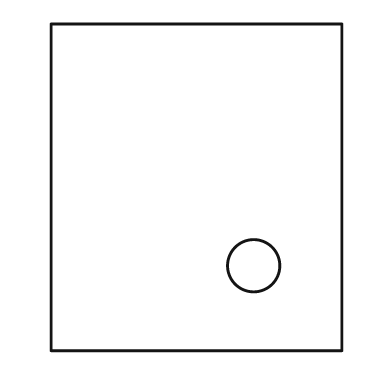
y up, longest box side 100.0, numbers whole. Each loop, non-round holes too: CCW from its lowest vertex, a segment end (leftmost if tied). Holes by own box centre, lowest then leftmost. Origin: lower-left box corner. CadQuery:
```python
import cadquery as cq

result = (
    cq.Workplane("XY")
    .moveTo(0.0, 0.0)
    .lineTo(89.0, 0.0)
    .lineTo(89.0, 100.0)
    .lineTo(0.0, 100.0)
    .close()
    .moveTo(62.0, 26.0)
    .circle(8.0)
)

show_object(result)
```